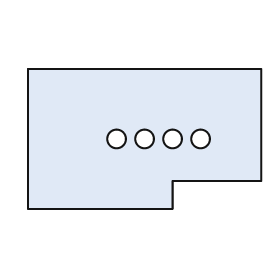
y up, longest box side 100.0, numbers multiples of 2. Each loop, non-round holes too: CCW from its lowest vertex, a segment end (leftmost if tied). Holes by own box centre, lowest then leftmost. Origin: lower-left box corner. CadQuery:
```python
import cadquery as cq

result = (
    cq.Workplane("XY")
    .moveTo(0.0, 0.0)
    .lineTo(62.0, 0.0)
    .lineTo(62.0, 12.0)
    .lineTo(100.0, 12.0)
    .lineTo(100.0, 60.0)
    .lineTo(0.0, 60.0)
    .close()
    .moveTo(38.0, 30.0)
    .circle(4.0)
    .moveTo(50.0, 30.0)
    .circle(4.0)
    .moveTo(62.0, 30.0)
    .circle(4.0)
    .moveTo(74.0, 30.0)
    .circle(4.0)
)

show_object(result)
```